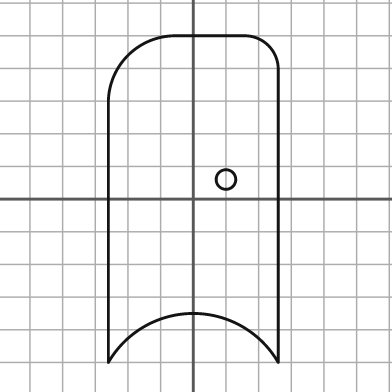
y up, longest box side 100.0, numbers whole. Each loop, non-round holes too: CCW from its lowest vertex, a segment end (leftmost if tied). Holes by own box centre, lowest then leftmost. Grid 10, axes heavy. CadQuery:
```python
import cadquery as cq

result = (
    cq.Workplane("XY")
    .moveTo(-26.0, -50.0)
    .threePointArc((0.0, -35.0), (26.0, -50.0))
    .lineTo(26.0, 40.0)
    .threePointArc((23.0, 47.0), (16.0, 50.0))
    .lineTo(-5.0, 50.0)
    .threePointArc((-20.0, 44.0), (-26.0, 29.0))
    .close()
    .moveTo(10.0, 6.0)
    .circle(3.0)
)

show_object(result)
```